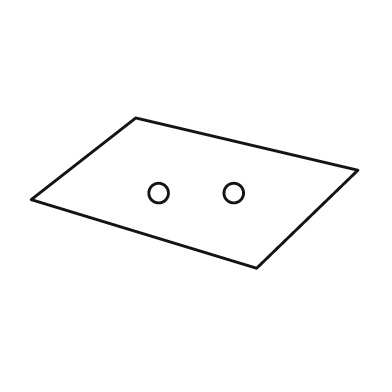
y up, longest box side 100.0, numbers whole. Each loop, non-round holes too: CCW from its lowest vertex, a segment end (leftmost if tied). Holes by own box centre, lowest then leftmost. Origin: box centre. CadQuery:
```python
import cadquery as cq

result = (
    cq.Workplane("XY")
    .moveTo(19.0, -23.0)
    .lineTo(50.0, 7.0)
    .lineTo(-18.0, 23.0)
    .lineTo(-50.0, -2.0)
    .close()
    .moveTo(-11.0, 0.0)
    .circle(3.0)
    .moveTo(12.0, 0.0)
    .circle(3.0)
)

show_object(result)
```